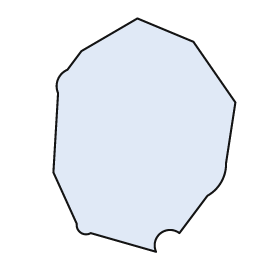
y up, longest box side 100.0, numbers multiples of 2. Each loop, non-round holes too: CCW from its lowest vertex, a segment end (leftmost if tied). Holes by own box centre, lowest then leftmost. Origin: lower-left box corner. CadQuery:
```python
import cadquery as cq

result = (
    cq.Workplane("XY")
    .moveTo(44.0, 0.0)
    .threePointArc((46.0, 8.0), (54.0, 8.0))
    .lineTo(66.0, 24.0)
    .threePointArc((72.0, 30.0), (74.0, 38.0))
    .lineTo(78.0, 64.0)
    .lineTo(60.0, 90.0)
    .lineTo(36.0, 100.0)
    .lineTo(12.0, 86.0)
    .lineTo(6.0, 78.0)
    .threePointArc((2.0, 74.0), (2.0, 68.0))
    .lineTo(0.0, 34.0)
    .lineTo(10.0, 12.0)
    .threePointArc((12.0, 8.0), (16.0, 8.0))
    .close()
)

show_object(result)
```